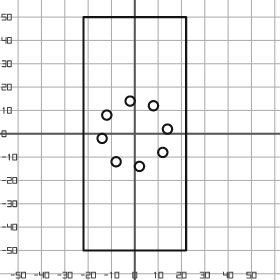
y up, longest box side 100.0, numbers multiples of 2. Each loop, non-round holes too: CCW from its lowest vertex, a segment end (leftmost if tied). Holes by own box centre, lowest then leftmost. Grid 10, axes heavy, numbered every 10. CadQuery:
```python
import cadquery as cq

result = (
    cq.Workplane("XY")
    .moveTo(-22.0, -50.0)
    .lineTo(22.0, -50.0)
    .lineTo(22.0, 50.0)
    .lineTo(-22.0, 50.0)
    .close()
    .moveTo(2.0, -14.0)
    .circle(2.0)
    .moveTo(-8.0, -12.0)
    .circle(2.0)
    .moveTo(12.0, -8.0)
    .circle(2.0)
    .moveTo(-14.0, -2.0)
    .circle(2.0)
    .moveTo(14.0, 2.0)
    .circle(2.0)
    .moveTo(-12.0, 8.0)
    .circle(2.0)
    .moveTo(8.0, 12.0)
    .circle(2.0)
    .moveTo(-2.0, 14.0)
    .circle(2.0)
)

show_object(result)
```